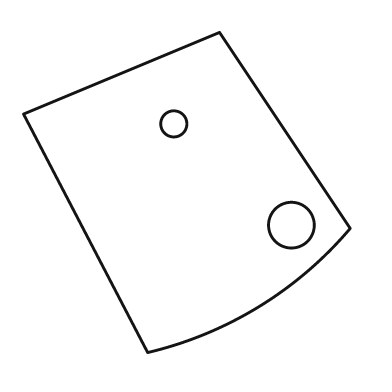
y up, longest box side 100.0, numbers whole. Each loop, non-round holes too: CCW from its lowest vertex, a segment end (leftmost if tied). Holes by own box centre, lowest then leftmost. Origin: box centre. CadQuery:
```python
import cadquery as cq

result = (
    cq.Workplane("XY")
    .moveTo(-12.0, -49.0)
    .threePointArc((22.0, -35.0), (50.0, -11.0))
    .lineTo(10.0, 49.0)
    .lineTo(-50.0, 24.0)
    .close()
    .moveTo(32.0, -10.0)
    .circle(7.0)
    .moveTo(-4.0, 21.0)
    .circle(4.0)
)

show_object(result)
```